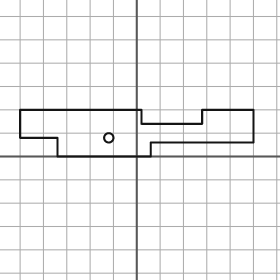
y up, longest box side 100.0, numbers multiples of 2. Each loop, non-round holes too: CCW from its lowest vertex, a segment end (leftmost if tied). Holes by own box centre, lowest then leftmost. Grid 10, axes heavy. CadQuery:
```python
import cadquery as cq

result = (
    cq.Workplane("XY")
    .moveTo(-34.0, 0.0)
    .lineTo(6.0, 0.0)
    .lineTo(6.0, 6.0)
    .lineTo(50.0, 6.0)
    .lineTo(50.0, 20.0)
    .lineTo(28.0, 20.0)
    .lineTo(28.0, 14.0)
    .lineTo(2.0, 14.0)
    .lineTo(2.0, 20.0)
    .lineTo(-50.0, 20.0)
    .lineTo(-50.0, 8.0)
    .lineTo(-34.0, 8.0)
    .close()
    .moveTo(-12.0, 8.0)
    .circle(2.0)
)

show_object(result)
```